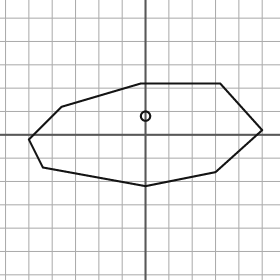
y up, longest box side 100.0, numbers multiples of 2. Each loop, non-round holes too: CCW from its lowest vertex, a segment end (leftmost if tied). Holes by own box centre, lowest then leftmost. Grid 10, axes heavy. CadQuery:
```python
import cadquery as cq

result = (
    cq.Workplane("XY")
    .moveTo(0.0, -22.0)
    .lineTo(30.0, -16.0)
    .lineTo(50.0, 2.0)
    .lineTo(32.0, 22.0)
    .lineTo(-2.0, 22.0)
    .lineTo(-36.0, 12.0)
    .lineTo(-50.0, -2.0)
    .lineTo(-44.0, -14.0)
    .close()
    .moveTo(0.0, 8.0)
    .circle(2.0)
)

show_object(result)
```